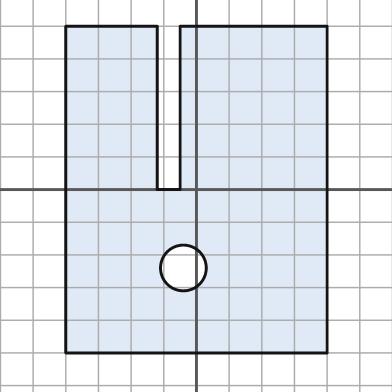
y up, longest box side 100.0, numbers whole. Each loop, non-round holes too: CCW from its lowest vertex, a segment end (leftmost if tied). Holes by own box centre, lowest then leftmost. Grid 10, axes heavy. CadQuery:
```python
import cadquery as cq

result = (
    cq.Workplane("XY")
    .moveTo(-40.0, -50.0)
    .lineTo(40.0, -50.0)
    .lineTo(40.0, 50.0)
    .lineTo(-5.0, 50.0)
    .lineTo(-5.0, 0.0)
    .lineTo(-12.0, 0.0)
    .lineTo(-12.0, 50.0)
    .lineTo(-40.0, 50.0)
    .close()
    .moveTo(-4.0, -24.0)
    .circle(7.0)
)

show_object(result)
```